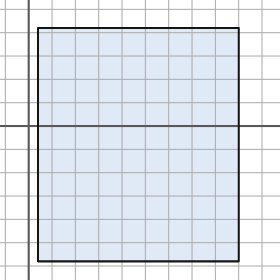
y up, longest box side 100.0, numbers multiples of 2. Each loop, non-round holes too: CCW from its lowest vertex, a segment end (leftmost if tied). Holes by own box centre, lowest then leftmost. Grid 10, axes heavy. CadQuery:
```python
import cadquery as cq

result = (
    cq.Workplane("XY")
    .moveTo(4.0, -58.0)
    .lineTo(90.0, -58.0)
    .lineTo(90.0, 42.0)
    .lineTo(4.0, 42.0)
    .close()
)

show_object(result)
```